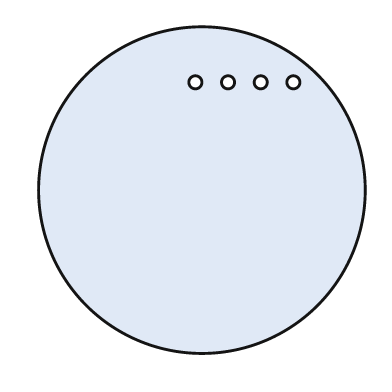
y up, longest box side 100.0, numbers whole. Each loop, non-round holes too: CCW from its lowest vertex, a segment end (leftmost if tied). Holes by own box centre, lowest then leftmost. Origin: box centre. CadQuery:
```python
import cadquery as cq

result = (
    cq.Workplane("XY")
    .moveTo(0.0, 0.0)
    .circle(50.0)
    .moveTo(-2.0, 33.0)
    .circle(2.0)
    .moveTo(8.0, 33.0)
    .circle(2.0)
    .moveTo(18.0, 33.0)
    .circle(2.0)
    .moveTo(28.0, 33.0)
    .circle(2.0)
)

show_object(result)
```